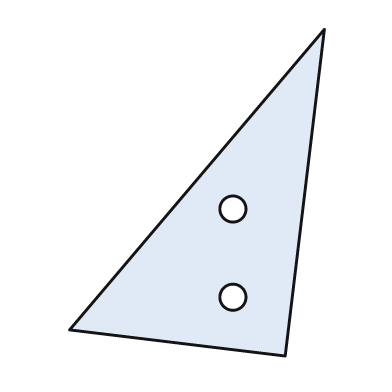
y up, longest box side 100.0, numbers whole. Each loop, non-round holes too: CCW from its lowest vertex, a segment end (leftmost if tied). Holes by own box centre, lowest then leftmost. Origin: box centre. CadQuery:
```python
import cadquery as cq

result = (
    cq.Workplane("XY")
    .moveTo(27.0, -50.0)
    .lineTo(39.0, 50.0)
    .lineTo(-39.0, -42.0)
    .close()
    .moveTo(11.0, -32.0)
    .circle(4.0)
    .moveTo(11.0, -5.0)
    .circle(4.0)
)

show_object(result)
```